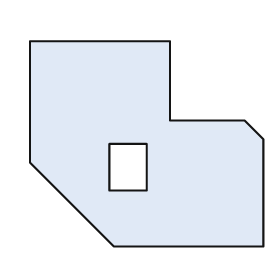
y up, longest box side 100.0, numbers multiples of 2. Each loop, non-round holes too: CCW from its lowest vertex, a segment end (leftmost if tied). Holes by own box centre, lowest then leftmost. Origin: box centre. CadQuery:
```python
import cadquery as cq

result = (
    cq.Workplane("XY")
    .moveTo(-14.0, -44.0)
    .lineTo(50.0, -44.0)
    .lineTo(50.0, 2.0)
    .lineTo(42.0, 10.0)
    .lineTo(10.0, 10.0)
    .lineTo(10.0, 44.0)
    .lineTo(-50.0, 44.0)
    .lineTo(-50.0, -8.0)
    .close()
    .moveTo(-16.0, -20.0)
    .lineTo(0.0, -20.0)
    .lineTo(0.0, 0.0)
    .lineTo(-16.0, 0.0)
    .close()
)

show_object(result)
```